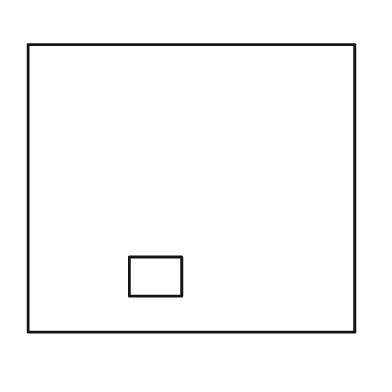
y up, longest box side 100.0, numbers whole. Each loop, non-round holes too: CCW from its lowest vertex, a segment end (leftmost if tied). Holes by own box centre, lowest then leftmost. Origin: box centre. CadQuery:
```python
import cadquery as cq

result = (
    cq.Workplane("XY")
    .moveTo(-50.0, -44.0)
    .lineTo(50.0, -44.0)
    .lineTo(50.0, 44.0)
    .lineTo(-50.0, 44.0)
    .close()
    .moveTo(-19.0, -33.0)
    .lineTo(-3.0, -33.0)
    .lineTo(-3.0, -21.0)
    .lineTo(-19.0, -21.0)
    .close()
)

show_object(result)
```